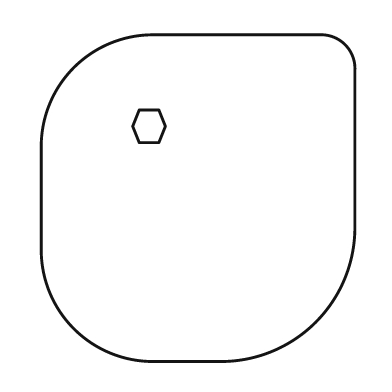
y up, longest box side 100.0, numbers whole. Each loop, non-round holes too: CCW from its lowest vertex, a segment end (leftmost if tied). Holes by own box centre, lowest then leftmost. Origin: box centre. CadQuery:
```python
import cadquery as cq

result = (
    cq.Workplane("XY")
    .moveTo(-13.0, -50.0)
    .lineTo(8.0, -50.0)
    .threePointArc((36.0, -38.0), (48.0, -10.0))
    .lineTo(48.0, 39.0)
    .threePointArc((45.0, 47.0), (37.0, 50.0))
    .lineTo(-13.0, 50.0)
    .threePointArc((-38.0, 40.0), (-48.0, 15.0))
    .lineTo(-48.0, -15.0)
    .threePointArc((-38.0, -40.0), (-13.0, -50.0))
    .close()
    .moveTo(-18.0, 17.0)
    .lineTo(-12.0, 17.0)
    .lineTo(-10.0, 22.0)
    .lineTo(-12.0, 27.0)
    .lineTo(-18.0, 27.0)
    .lineTo(-20.0, 22.0)
    .close()
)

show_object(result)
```